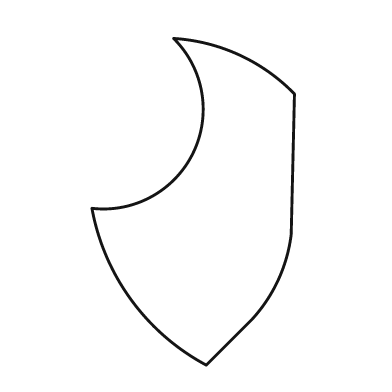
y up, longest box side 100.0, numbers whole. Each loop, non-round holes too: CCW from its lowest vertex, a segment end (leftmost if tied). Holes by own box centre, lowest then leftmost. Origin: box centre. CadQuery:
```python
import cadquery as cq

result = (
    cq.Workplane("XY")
    .moveTo(4.0, -50.0)
    .lineTo(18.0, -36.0)
    .threePointArc((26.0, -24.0), (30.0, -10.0))
    .lineTo(31.0, 33.0)
    .threePointArc((14.0, 45.0), (-6.0, 50.0))
    .threePointArc((0.0, 15.0), (-31.0, -2.0))
    .threePointArc((-19.0, -30.0), (4.0, -50.0))
    .close()
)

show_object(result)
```